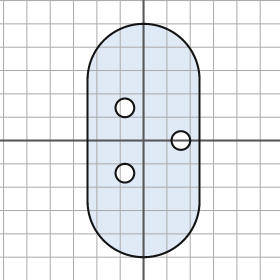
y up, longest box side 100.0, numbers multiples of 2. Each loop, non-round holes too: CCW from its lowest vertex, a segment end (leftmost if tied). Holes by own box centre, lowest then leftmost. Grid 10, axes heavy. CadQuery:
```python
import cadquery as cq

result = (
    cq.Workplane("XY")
    .moveTo(-24.0, -26.0)
    .threePointArc((0.0, -50.0), (24.0, -26.0))
    .lineTo(24.0, 26.0)
    .threePointArc((0.0, 50.0), (-24.0, 26.0))
    .close()
    .moveTo(-8.0, -14.0)
    .circle(4.0)
    .moveTo(16.0, 0.0)
    .circle(4.0)
    .moveTo(-8.0, 14.0)
    .circle(4.0)
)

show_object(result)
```